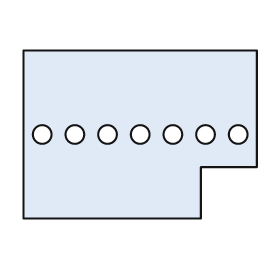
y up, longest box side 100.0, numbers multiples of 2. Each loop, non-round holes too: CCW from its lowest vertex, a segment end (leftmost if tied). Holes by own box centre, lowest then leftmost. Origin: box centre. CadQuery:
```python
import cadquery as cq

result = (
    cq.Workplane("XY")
    .moveTo(-50.0, -36.0)
    .lineTo(26.0, -36.0)
    .lineTo(26.0, -14.0)
    .lineTo(50.0, -14.0)
    .lineTo(50.0, 36.0)
    .lineTo(-50.0, 36.0)
    .close()
    .moveTo(-42.0, 0.0)
    .circle(4.0)
    .moveTo(-28.0, 0.0)
    .circle(4.0)
    .moveTo(-14.0, 0.0)
    .circle(4.0)
    .moveTo(0.0, 0.0)
    .circle(4.0)
    .moveTo(14.0, 0.0)
    .circle(4.0)
    .moveTo(28.0, 0.0)
    .circle(4.0)
    .moveTo(42.0, 0.0)
    .circle(4.0)
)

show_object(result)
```